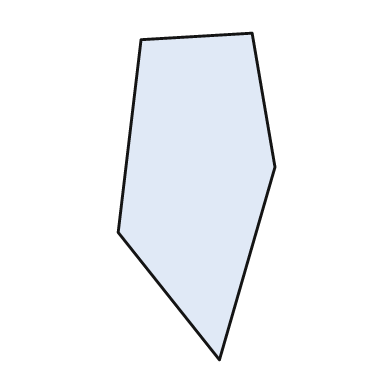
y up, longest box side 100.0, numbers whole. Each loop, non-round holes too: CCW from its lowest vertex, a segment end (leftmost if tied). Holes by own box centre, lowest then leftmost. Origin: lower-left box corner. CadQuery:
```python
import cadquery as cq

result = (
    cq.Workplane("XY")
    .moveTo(31.0, 0.0)
    .lineTo(48.0, 59.0)
    .lineTo(41.0, 100.0)
    .lineTo(7.0, 98.0)
    .lineTo(0.0, 39.0)
    .close()
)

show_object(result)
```